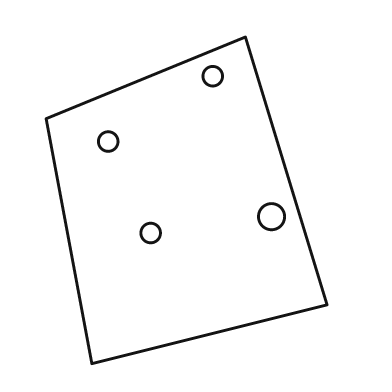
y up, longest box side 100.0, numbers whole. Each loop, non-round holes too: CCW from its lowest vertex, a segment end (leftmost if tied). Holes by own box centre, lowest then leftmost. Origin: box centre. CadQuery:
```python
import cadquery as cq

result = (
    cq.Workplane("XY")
    .moveTo(-29.0, -50.0)
    .lineTo(43.0, -32.0)
    .lineTo(18.0, 50.0)
    .lineTo(-43.0, 25.0)
    .close()
    .moveTo(-11.0, -10.0)
    .circle(3.0)
    .moveTo(26.0, -5.0)
    .circle(4.0)
    .moveTo(-24.0, 18.0)
    .circle(3.0)
    .moveTo(8.0, 38.0)
    .circle(3.0)
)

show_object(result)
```